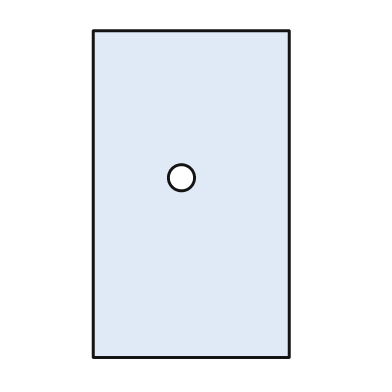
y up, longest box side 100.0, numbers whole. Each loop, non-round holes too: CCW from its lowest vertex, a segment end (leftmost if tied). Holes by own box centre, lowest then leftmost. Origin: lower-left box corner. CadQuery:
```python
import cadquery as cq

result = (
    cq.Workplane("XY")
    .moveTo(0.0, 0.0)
    .lineTo(60.0, 0.0)
    .lineTo(60.0, 100.0)
    .lineTo(0.0, 100.0)
    .close()
    .moveTo(27.0, 55.0)
    .circle(4.0)
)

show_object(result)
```